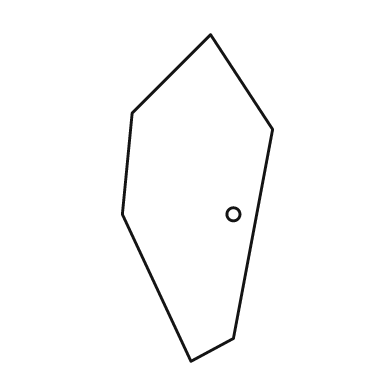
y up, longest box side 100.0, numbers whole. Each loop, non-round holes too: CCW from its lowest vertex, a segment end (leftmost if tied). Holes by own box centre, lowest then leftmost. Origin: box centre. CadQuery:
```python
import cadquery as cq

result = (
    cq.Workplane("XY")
    .moveTo(-2.0, -50.0)
    .lineTo(11.0, -43.0)
    .lineTo(23.0, 21.0)
    .lineTo(4.0, 50.0)
    .lineTo(-20.0, 26.0)
    .lineTo(-23.0, -5.0)
    .close()
    .moveTo(11.0, -5.0)
    .circle(2.0)
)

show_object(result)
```